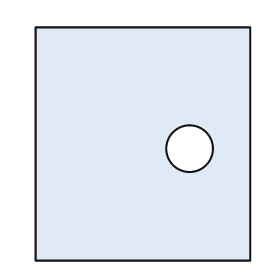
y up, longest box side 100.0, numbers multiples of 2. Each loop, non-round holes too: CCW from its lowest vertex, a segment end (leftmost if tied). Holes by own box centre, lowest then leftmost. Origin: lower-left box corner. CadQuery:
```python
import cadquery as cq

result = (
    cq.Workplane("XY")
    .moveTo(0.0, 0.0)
    .lineTo(92.0, 0.0)
    .lineTo(92.0, 100.0)
    .lineTo(0.0, 100.0)
    .close()
    .moveTo(66.0, 48.0)
    .circle(10.0)
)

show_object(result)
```